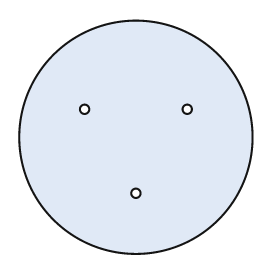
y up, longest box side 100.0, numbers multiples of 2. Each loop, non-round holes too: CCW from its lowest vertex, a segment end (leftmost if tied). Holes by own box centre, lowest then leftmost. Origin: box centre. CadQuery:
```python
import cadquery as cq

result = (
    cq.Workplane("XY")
    .moveTo(0.0, 0.0)
    .circle(50.0)
    .moveTo(0.0, -24.0)
    .circle(2.0)
    .moveTo(-22.0, 12.0)
    .circle(2.0)
    .moveTo(22.0, 12.0)
    .circle(2.0)
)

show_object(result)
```